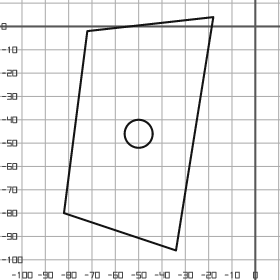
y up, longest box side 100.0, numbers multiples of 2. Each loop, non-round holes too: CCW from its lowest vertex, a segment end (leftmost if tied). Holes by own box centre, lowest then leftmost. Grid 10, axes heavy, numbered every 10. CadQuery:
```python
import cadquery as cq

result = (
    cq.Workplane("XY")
    .moveTo(-34.0, -96.0)
    .lineTo(-18.0, 4.0)
    .lineTo(-72.0, -2.0)
    .lineTo(-82.0, -80.0)
    .close()
    .moveTo(-50.0, -46.0)
    .circle(6.0)
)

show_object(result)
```